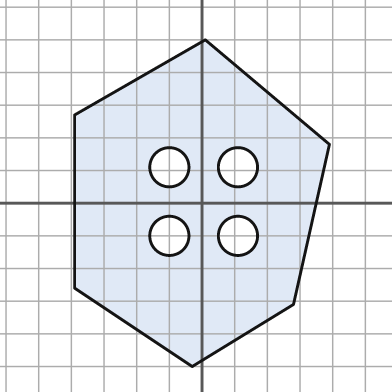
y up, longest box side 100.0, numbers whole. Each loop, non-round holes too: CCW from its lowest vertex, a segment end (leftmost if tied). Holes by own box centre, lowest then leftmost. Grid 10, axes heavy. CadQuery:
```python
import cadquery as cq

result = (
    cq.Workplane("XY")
    .moveTo(-3.0, -50.0)
    .lineTo(28.0, -31.0)
    .lineTo(39.0, 18.0)
    .lineTo(1.0, 50.0)
    .lineTo(-39.0, 27.0)
    .lineTo(-39.0, -26.0)
    .close()
    .moveTo(-10.0, -10.0)
    .circle(6.0)
    .moveTo(11.0, -10.0)
    .circle(6.0)
    .moveTo(-10.0, 11.0)
    .circle(6.0)
    .moveTo(11.0, 11.0)
    .circle(6.0)
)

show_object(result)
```